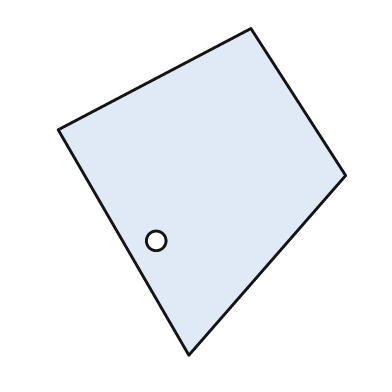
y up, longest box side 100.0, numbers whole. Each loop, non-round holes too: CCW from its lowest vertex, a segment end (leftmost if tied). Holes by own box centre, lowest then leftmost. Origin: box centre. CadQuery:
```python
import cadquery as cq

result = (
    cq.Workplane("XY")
    .moveTo(-4.0, -50.0)
    .lineTo(44.0, 5.0)
    .lineTo(15.0, 50.0)
    .lineTo(-44.0, 19.0)
    .close()
    .moveTo(-14.0, -15.0)
    .circle(3.0)
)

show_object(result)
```